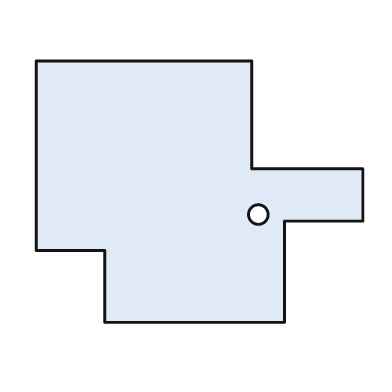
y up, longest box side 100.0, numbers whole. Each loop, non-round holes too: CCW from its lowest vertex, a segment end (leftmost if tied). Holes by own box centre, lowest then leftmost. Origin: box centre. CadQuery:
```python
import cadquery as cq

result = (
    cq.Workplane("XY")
    .moveTo(-29.0, -40.0)
    .lineTo(26.0, -40.0)
    .lineTo(26.0, -9.0)
    .lineTo(50.0, -9.0)
    .lineTo(50.0, 7.0)
    .lineTo(16.0, 7.0)
    .lineTo(16.0, 40.0)
    .lineTo(-50.0, 40.0)
    .lineTo(-50.0, -18.0)
    .lineTo(-29.0, -18.0)
    .close()
    .moveTo(18.0, -7.0)
    .circle(3.0)
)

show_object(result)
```